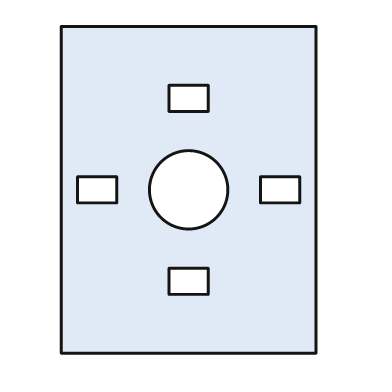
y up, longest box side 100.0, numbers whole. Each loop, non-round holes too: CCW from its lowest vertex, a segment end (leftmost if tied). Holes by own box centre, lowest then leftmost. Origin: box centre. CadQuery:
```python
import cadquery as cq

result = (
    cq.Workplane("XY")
    .moveTo(-39.0, -50.0)
    .lineTo(39.0, -50.0)
    .lineTo(39.0, 50.0)
    .lineTo(-39.0, 50.0)
    .close()
    .moveTo(-6.0, -32.0)
    .lineTo(6.0, -32.0)
    .lineTo(6.0, -24.0)
    .lineTo(-6.0, -24.0)
    .close()
    .moveTo(-34.0, -4.0)
    .lineTo(-22.0, -4.0)
    .lineTo(-22.0, 4.0)
    .lineTo(-34.0, 4.0)
    .close()
    .moveTo(0.0, 0.0)
    .circle(12.0)
    .moveTo(22.0, -4.0)
    .lineTo(34.0, -4.0)
    .lineTo(34.0, 4.0)
    .lineTo(22.0, 4.0)
    .close()
    .moveTo(-6.0, 24.0)
    .lineTo(6.0, 24.0)
    .lineTo(6.0, 32.0)
    .lineTo(-6.0, 32.0)
    .close()
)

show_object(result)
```